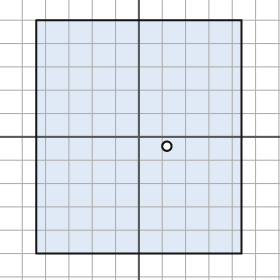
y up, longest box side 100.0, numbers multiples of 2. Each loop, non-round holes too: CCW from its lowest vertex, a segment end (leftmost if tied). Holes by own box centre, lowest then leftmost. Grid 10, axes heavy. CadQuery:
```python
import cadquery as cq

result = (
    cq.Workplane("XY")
    .moveTo(-44.0, -50.0)
    .lineTo(44.0, -50.0)
    .lineTo(44.0, 50.0)
    .lineTo(-44.0, 50.0)
    .close()
    .moveTo(12.0, -4.0)
    .circle(2.0)
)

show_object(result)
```